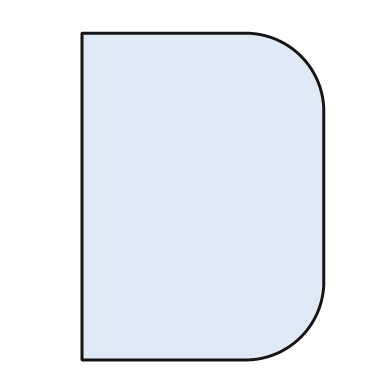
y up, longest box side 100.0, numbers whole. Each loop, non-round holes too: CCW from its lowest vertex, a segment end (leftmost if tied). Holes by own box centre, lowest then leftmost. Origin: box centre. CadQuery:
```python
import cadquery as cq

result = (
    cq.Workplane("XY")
    .moveTo(-37.0, -50.0)
    .lineTo(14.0, -50.0)
    .threePointArc((30.0, -43.0), (37.0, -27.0))
    .lineTo(37.0, 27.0)
    .threePointArc((30.0, 43.0), (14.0, 50.0))
    .lineTo(-37.0, 50.0)
    .close()
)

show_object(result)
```